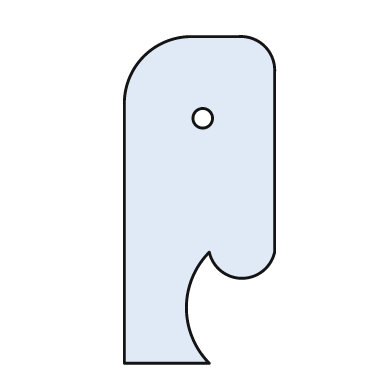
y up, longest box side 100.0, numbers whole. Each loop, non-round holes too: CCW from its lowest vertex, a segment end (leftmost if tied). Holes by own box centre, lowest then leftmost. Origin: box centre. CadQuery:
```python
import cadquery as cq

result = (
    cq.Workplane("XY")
    .moveTo(-23.0, -50.0)
    .lineTo(3.0, -50.0)
    .threePointArc((-4.0, -33.0), (3.0, -16.0))
    .threePointArc((13.0, -24.0), (23.0, -16.0))
    .lineTo(23.0, 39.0)
    .threePointArc((20.0, 47.0), (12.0, 50.0))
    .lineTo(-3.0, 50.0)
    .threePointArc((-17.0, 44.0), (-23.0, 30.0))
    .close()
    .moveTo(1.0, 25.0)
    .circle(3.0)
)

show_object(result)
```